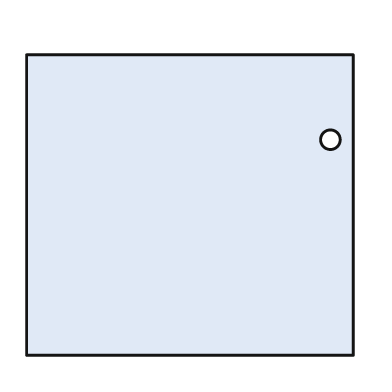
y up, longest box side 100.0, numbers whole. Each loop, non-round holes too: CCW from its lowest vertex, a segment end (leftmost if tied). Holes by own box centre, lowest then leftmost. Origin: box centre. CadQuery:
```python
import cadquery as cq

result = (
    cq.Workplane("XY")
    .moveTo(-50.0, -46.0)
    .lineTo(50.0, -46.0)
    .lineTo(50.0, 46.0)
    .lineTo(-50.0, 46.0)
    .close()
    .moveTo(43.0, 20.0)
    .circle(3.0)
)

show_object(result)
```